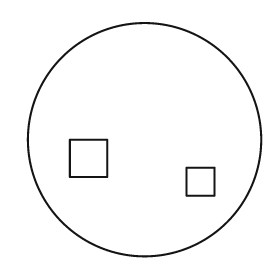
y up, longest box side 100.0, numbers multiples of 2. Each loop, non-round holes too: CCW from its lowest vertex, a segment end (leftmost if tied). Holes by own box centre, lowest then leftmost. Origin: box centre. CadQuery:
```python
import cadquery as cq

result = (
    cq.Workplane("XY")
    .moveTo(0.0, 0.0)
    .circle(50.0)
    .moveTo(18.0, -24.0)
    .lineTo(30.0, -24.0)
    .lineTo(30.0, -12.0)
    .lineTo(18.0, -12.0)
    .close()
    .moveTo(-32.0, -16.0)
    .lineTo(-16.0, -16.0)
    .lineTo(-16.0, 0.0)
    .lineTo(-32.0, 0.0)
    .close()
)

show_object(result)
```